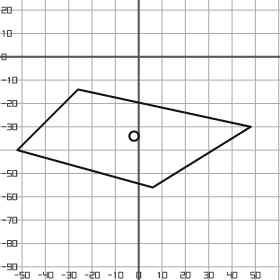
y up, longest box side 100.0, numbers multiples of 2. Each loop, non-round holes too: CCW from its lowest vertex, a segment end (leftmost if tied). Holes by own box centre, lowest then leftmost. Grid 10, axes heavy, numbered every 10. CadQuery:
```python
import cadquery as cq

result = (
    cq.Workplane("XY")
    .moveTo(6.0, -56.0)
    .lineTo(48.0, -30.0)
    .lineTo(-26.0, -14.0)
    .lineTo(-52.0, -40.0)
    .close()
    .moveTo(-2.0, -34.0)
    .circle(2.0)
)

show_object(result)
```